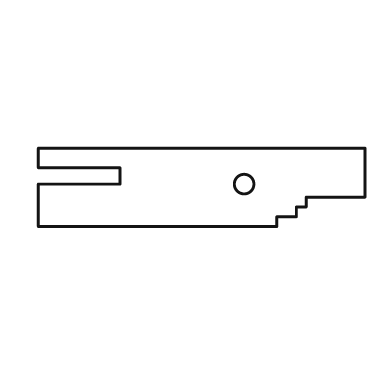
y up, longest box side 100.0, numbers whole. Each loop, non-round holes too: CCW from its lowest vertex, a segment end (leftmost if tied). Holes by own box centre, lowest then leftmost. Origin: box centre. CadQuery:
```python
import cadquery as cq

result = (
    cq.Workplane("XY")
    .moveTo(-50.0, -12.0)
    .lineTo(23.0, -12.0)
    .lineTo(23.0, -9.0)
    .lineTo(29.0, -9.0)
    .lineTo(29.0, -6.0)
    .lineTo(32.0, -6.0)
    .lineTo(32.0, -3.0)
    .lineTo(50.0, -3.0)
    .lineTo(50.0, 12.0)
    .lineTo(-50.0, 12.0)
    .lineTo(-50.0, 6.0)
    .lineTo(-25.0, 6.0)
    .lineTo(-25.0, 1.0)
    .lineTo(-50.0, 1.0)
    .close()
    .moveTo(13.0, 1.0)
    .circle(3.0)
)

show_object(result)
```